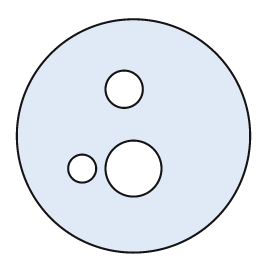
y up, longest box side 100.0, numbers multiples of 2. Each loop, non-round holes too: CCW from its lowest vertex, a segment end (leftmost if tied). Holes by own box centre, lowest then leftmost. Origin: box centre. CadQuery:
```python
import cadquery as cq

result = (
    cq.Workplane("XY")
    .moveTo(0.0, 0.0)
    .circle(50.0)
    .moveTo(-22.0, -14.0)
    .circle(6.0)
    .moveTo(0.0, -14.0)
    .circle(12.0)
    .moveTo(-4.0, 20.0)
    .circle(8.0)
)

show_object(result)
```